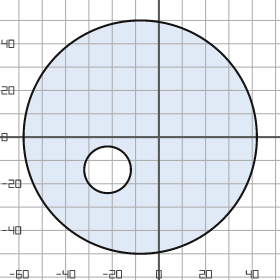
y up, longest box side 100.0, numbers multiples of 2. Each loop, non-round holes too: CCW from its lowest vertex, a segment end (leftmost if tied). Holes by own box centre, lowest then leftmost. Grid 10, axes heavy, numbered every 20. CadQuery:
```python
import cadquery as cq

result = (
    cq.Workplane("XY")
    .moveTo(-8.0, 0.0)
    .circle(50.0)
    .moveTo(-22.0, -14.0)
    .circle(10.0)
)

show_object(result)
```